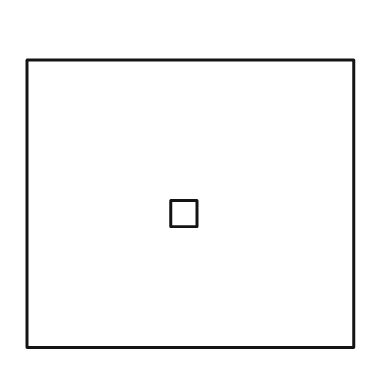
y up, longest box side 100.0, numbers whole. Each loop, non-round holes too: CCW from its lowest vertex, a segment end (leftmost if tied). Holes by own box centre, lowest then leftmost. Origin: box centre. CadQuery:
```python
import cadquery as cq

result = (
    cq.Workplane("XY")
    .moveTo(-50.0, -44.0)
    .lineTo(50.0, -44.0)
    .lineTo(50.0, 44.0)
    .lineTo(-50.0, 44.0)
    .close()
    .moveTo(-6.0, -7.0)
    .lineTo(2.0, -7.0)
    .lineTo(2.0, 1.0)
    .lineTo(-6.0, 1.0)
    .close()
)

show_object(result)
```